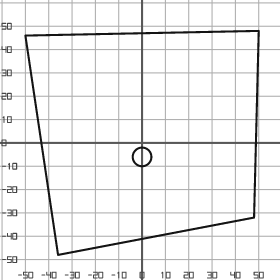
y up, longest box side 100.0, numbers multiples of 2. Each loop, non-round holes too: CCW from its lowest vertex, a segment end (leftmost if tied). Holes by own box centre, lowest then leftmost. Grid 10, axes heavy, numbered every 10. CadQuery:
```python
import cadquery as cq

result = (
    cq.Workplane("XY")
    .moveTo(-36.0, -48.0)
    .lineTo(48.0, -32.0)
    .lineTo(50.0, 48.0)
    .lineTo(-50.0, 46.0)
    .close()
    .moveTo(0.0, -6.0)
    .circle(4.0)
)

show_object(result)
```